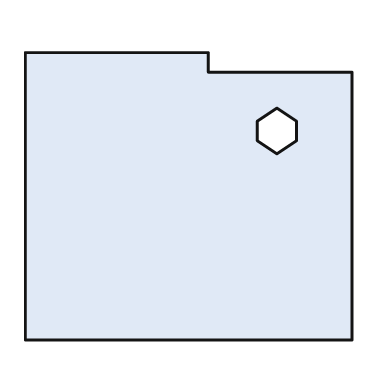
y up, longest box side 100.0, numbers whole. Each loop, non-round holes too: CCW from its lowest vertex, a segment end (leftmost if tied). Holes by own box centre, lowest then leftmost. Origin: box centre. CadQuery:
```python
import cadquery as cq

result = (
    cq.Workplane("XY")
    .moveTo(-50.0, -44.0)
    .lineTo(50.0, -44.0)
    .lineTo(50.0, 38.0)
    .lineTo(6.0, 38.0)
    .lineTo(6.0, 44.0)
    .lineTo(-50.0, 44.0)
    .close()
    .moveTo(27.0, 13.0)
    .lineTo(33.0, 17.0)
    .lineTo(33.0, 23.0)
    .lineTo(27.0, 27.0)
    .lineTo(21.0, 23.0)
    .lineTo(21.0, 17.0)
    .close()
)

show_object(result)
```